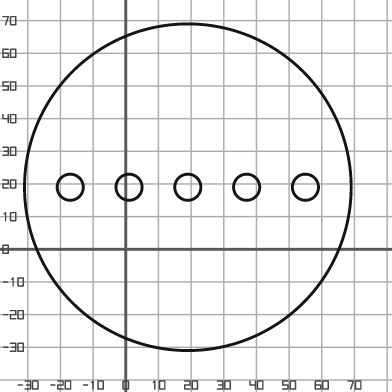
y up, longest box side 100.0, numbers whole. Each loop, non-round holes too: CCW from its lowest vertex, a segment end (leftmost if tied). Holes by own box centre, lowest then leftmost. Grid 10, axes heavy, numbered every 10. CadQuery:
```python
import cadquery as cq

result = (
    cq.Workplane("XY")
    .moveTo(19.0, 19.0)
    .circle(50.0)
    .moveTo(-17.0, 19.0)
    .circle(4.0)
    .moveTo(1.0, 19.0)
    .circle(4.0)
    .moveTo(19.0, 19.0)
    .circle(4.0)
    .moveTo(37.0, 19.0)
    .circle(4.0)
    .moveTo(55.0, 19.0)
    .circle(4.0)
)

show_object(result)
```